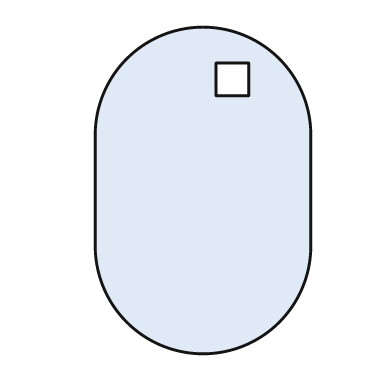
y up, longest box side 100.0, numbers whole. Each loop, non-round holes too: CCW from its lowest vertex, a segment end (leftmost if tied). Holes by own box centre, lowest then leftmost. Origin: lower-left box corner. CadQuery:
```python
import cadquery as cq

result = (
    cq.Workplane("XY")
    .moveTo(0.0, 33.0)
    .threePointArc((33.0, 0.0), (66.0, 33.0))
    .lineTo(66.0, 67.0)
    .threePointArc((33.0, 100.0), (0.0, 67.0))
    .close()
    .moveTo(37.0, 79.0)
    .lineTo(47.0, 79.0)
    .lineTo(47.0, 89.0)
    .lineTo(37.0, 89.0)
    .close()
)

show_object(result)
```